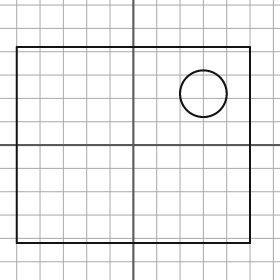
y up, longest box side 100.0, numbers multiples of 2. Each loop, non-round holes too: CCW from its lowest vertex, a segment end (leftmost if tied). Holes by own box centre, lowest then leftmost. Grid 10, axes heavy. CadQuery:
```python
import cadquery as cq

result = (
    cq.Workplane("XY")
    .moveTo(-50.0, -42.0)
    .lineTo(50.0, -42.0)
    .lineTo(50.0, 42.0)
    .lineTo(-50.0, 42.0)
    .close()
    .moveTo(30.0, 22.0)
    .circle(10.0)
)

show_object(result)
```